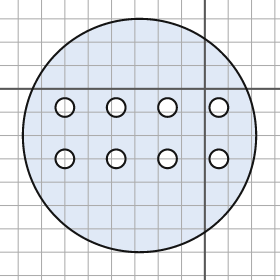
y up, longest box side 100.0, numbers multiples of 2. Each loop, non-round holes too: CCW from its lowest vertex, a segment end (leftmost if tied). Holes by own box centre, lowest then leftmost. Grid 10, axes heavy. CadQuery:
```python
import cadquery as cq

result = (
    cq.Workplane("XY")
    .moveTo(-28.0, -20.0)
    .circle(50.0)
    .moveTo(-60.0, -30.0)
    .circle(4.0)
    .moveTo(-38.0, -30.0)
    .circle(4.0)
    .moveTo(-16.0, -30.0)
    .circle(4.0)
    .moveTo(6.0, -30.0)
    .circle(4.0)
    .moveTo(-60.0, -8.0)
    .circle(4.0)
    .moveTo(-38.0, -8.0)
    .circle(4.0)
    .moveTo(-16.0, -8.0)
    .circle(4.0)
    .moveTo(6.0, -8.0)
    .circle(4.0)
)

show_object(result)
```